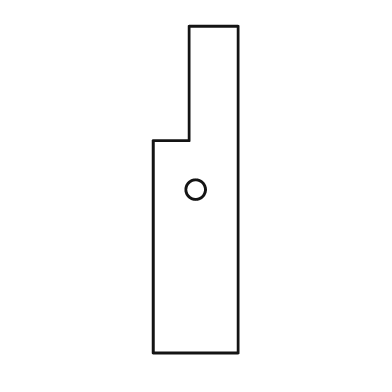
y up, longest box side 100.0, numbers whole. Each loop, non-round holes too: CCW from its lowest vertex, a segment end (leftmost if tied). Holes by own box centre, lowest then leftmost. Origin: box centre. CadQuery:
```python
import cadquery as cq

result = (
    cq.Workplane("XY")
    .moveTo(-13.0, -50.0)
    .lineTo(13.0, -50.0)
    .lineTo(13.0, 50.0)
    .lineTo(-2.0, 50.0)
    .lineTo(-2.0, 15.0)
    .lineTo(-13.0, 15.0)
    .close()
    .moveTo(0.0, 0.0)
    .circle(3.0)
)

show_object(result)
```